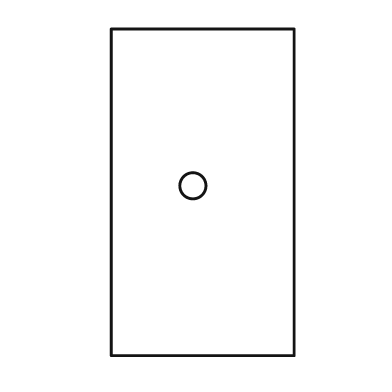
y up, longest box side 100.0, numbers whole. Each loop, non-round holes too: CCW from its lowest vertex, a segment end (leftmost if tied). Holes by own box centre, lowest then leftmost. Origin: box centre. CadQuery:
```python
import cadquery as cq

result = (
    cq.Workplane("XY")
    .moveTo(-28.0, -50.0)
    .lineTo(28.0, -50.0)
    .lineTo(28.0, 50.0)
    .lineTo(-28.0, 50.0)
    .close()
    .moveTo(-3.0, 2.0)
    .circle(4.0)
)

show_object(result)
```